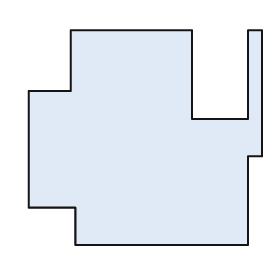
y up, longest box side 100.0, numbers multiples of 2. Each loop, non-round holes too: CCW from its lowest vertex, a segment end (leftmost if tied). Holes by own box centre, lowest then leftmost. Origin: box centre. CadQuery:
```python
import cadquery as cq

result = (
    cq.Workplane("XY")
    .moveTo(-30.0, -46.0)
    .lineTo(44.0, -46.0)
    .lineTo(44.0, -8.0)
    .lineTo(50.0, -8.0)
    .lineTo(50.0, 46.0)
    .lineTo(44.0, 46.0)
    .lineTo(44.0, 8.0)
    .lineTo(20.0, 8.0)
    .lineTo(20.0, 46.0)
    .lineTo(-32.0, 46.0)
    .lineTo(-32.0, 20.0)
    .lineTo(-50.0, 20.0)
    .lineTo(-50.0, -30.0)
    .lineTo(-30.0, -30.0)
    .close()
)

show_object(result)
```